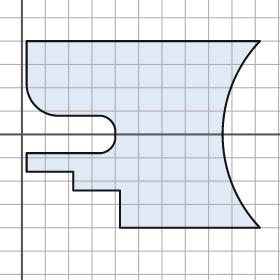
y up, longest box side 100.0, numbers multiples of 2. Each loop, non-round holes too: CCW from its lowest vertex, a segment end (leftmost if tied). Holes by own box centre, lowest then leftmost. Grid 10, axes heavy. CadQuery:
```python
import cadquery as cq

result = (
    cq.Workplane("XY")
    .moveTo(42.0, -40.0)
    .lineTo(102.0, -40.0)
    .threePointArc((86.0, 0.0), (102.0, 40.0))
    .lineTo(2.0, 40.0)
    .lineTo(2.0, 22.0)
    .threePointArc((6.0, 12.0), (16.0, 8.0))
    .lineTo(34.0, 8.0)
    .threePointArc((38.0, 6.0), (40.0, 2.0))
    .lineTo(40.0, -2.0)
    .threePointArc((38.0, -6.0), (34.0, -8.0))
    .lineTo(2.0, -8.0)
    .lineTo(2.0, -16.0)
    .lineTo(22.0, -16.0)
    .lineTo(22.0, -24.0)
    .lineTo(42.0, -24.0)
    .close()
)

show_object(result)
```